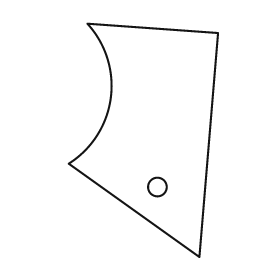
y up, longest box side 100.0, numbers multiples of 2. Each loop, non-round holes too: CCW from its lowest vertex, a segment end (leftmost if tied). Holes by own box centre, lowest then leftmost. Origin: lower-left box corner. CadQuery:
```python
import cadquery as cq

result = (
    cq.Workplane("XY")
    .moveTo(56.0, 0.0)
    .lineTo(64.0, 96.0)
    .lineTo(8.0, 100.0)
    .threePointArc((18.0, 68.0), (0.0, 40.0))
    .close()
    .moveTo(38.0, 30.0)
    .circle(4.0)
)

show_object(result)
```